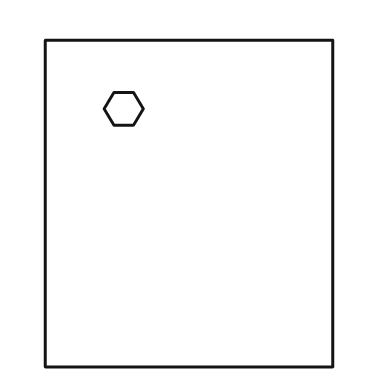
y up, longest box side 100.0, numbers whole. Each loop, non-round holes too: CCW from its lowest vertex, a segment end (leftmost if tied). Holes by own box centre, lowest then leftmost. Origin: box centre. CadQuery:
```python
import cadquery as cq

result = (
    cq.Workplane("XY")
    .moveTo(-44.0, -50.0)
    .lineTo(44.0, -50.0)
    .lineTo(44.0, 50.0)
    .lineTo(-44.0, 50.0)
    .close()
    .moveTo(-23.0, 24.0)
    .lineTo(-17.0, 24.0)
    .lineTo(-14.0, 29.0)
    .lineTo(-17.0, 34.0)
    .lineTo(-23.0, 34.0)
    .lineTo(-26.0, 29.0)
    .close()
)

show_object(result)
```